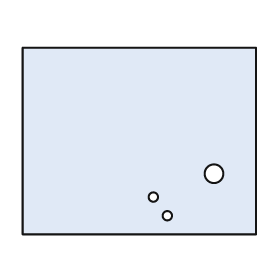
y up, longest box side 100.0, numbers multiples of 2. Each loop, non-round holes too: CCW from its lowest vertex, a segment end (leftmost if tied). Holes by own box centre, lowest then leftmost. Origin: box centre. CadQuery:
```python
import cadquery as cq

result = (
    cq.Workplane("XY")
    .moveTo(-50.0, -40.0)
    .lineTo(50.0, -40.0)
    .lineTo(50.0, 40.0)
    .lineTo(-50.0, 40.0)
    .close()
    .moveTo(12.0, -32.0)
    .circle(2.0)
    .moveTo(6.0, -24.0)
    .circle(2.0)
    .moveTo(32.0, -14.0)
    .circle(4.0)
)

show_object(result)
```